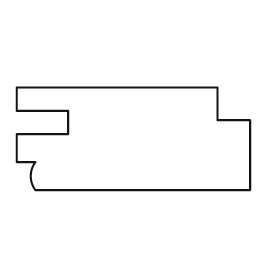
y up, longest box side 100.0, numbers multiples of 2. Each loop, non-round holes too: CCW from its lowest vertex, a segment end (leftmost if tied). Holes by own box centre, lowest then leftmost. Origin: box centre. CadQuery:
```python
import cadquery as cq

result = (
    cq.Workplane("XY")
    .moveTo(-42.0, -22.0)
    .lineTo(50.0, -22.0)
    .lineTo(50.0, 8.0)
    .lineTo(36.0, 8.0)
    .lineTo(36.0, 22.0)
    .lineTo(-50.0, 22.0)
    .lineTo(-50.0, 12.0)
    .lineTo(-28.0, 12.0)
    .lineTo(-28.0, 2.0)
    .lineTo(-50.0, 2.0)
    .lineTo(-50.0, -10.0)
    .lineTo(-42.0, -10.0)
    .threePointArc((-44.0, -16.0), (-42.0, -22.0))
    .close()
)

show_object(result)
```